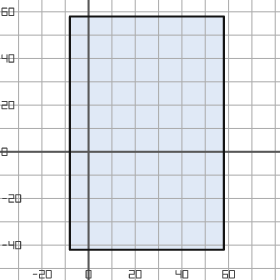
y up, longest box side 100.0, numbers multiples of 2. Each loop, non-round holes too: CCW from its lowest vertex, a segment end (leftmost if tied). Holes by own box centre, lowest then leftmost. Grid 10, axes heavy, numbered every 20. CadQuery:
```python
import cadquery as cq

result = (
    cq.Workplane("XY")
    .moveTo(-8.0, -42.0)
    .lineTo(58.0, -42.0)
    .lineTo(58.0, 58.0)
    .lineTo(-8.0, 58.0)
    .close()
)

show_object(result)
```